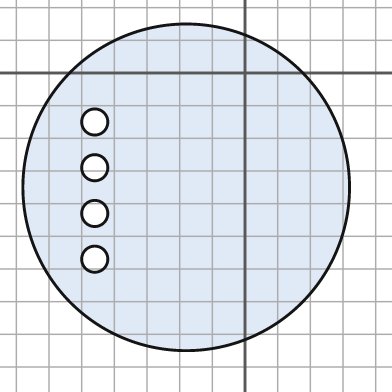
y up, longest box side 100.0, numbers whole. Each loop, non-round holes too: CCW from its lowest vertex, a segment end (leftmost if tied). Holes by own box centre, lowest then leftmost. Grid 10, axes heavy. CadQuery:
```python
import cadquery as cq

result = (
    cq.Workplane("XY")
    .moveTo(-18.0, -35.0)
    .circle(50.0)
    .moveTo(-46.0, -57.0)
    .circle(4.0)
    .moveTo(-46.0, -43.0)
    .circle(4.0)
    .moveTo(-46.0, -29.0)
    .circle(4.0)
    .moveTo(-46.0, -15.0)
    .circle(4.0)
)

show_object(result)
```